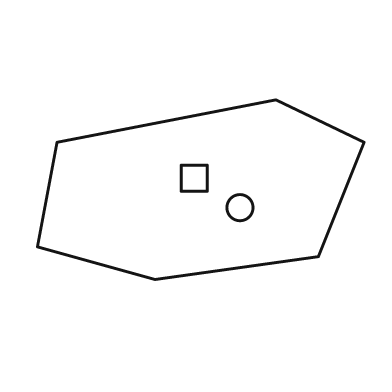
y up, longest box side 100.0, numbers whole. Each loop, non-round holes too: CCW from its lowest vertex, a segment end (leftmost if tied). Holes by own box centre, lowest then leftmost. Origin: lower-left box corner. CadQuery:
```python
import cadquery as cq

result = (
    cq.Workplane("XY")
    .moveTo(36.0, 0.0)
    .lineTo(86.0, 7.0)
    .lineTo(100.0, 42.0)
    .lineTo(73.0, 55.0)
    .lineTo(6.0, 42.0)
    .lineTo(0.0, 10.0)
    .close()
    .moveTo(62.0, 22.0)
    .circle(4.0)
    .moveTo(44.0, 27.0)
    .lineTo(52.0, 27.0)
    .lineTo(52.0, 35.0)
    .lineTo(44.0, 35.0)
    .close()
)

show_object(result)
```